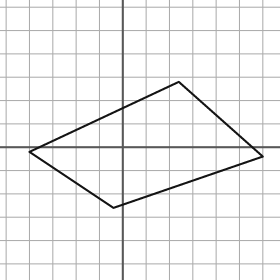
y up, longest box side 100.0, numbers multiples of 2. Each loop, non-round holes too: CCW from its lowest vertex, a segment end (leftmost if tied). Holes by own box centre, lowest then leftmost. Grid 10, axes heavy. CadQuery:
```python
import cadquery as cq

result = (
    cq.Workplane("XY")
    .moveTo(-4.0, -26.0)
    .lineTo(60.0, -4.0)
    .lineTo(24.0, 28.0)
    .lineTo(-40.0, -2.0)
    .close()
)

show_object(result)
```